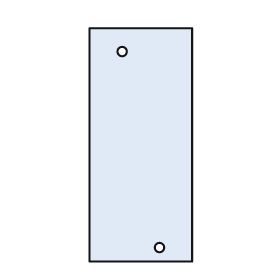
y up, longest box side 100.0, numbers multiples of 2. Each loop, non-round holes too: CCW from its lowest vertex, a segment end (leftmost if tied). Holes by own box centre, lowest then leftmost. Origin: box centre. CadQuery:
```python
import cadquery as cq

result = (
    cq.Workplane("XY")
    .moveTo(-22.0, -50.0)
    .lineTo(22.0, -50.0)
    .lineTo(22.0, 50.0)
    .lineTo(-22.0, 50.0)
    .close()
    .moveTo(8.0, -44.0)
    .circle(2.0)
    .moveTo(-8.0, 40.0)
    .circle(2.0)
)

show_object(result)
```